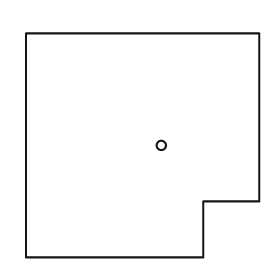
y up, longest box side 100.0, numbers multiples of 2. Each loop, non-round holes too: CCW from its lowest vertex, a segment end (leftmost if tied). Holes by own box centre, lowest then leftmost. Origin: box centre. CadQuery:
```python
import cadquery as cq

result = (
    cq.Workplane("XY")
    .moveTo(-50.0, -48.0)
    .lineTo(26.0, -48.0)
    .lineTo(26.0, -24.0)
    .lineTo(50.0, -24.0)
    .lineTo(50.0, 48.0)
    .lineTo(-50.0, 48.0)
    .close()
    .moveTo(8.0, 0.0)
    .circle(2.0)
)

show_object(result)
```